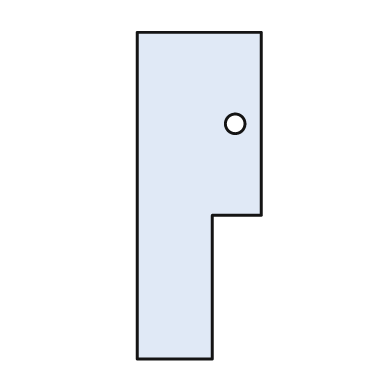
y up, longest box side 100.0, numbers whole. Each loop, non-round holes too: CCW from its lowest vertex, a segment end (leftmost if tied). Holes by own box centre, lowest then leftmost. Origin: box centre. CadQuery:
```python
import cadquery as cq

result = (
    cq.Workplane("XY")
    .moveTo(-19.0, -50.0)
    .lineTo(4.0, -50.0)
    .lineTo(4.0, -6.0)
    .lineTo(19.0, -6.0)
    .lineTo(19.0, 50.0)
    .lineTo(-19.0, 50.0)
    .close()
    .moveTo(11.0, 22.0)
    .circle(3.0)
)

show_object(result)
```